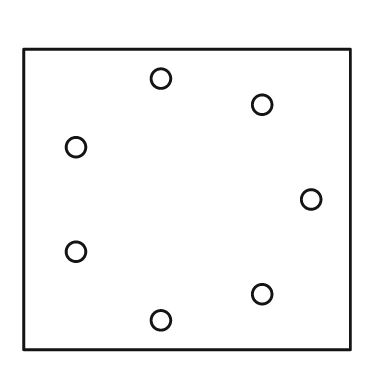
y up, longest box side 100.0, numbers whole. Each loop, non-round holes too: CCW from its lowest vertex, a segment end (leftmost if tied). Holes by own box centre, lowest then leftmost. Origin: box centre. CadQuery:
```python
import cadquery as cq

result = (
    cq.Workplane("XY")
    .moveTo(-50.0, -46.0)
    .lineTo(50.0, -46.0)
    .lineTo(50.0, 46.0)
    .lineTo(-50.0, 46.0)
    .close()
    .moveTo(-8.0, -37.0)
    .circle(3.0)
    .moveTo(23.0, -29.0)
    .circle(3.0)
    .moveTo(-34.0, -16.0)
    .circle(3.0)
    .moveTo(38.0, 0.0)
    .circle(3.0)
    .moveTo(-34.0, 16.0)
    .circle(3.0)
    .moveTo(23.0, 29.0)
    .circle(3.0)
    .moveTo(-8.0, 37.0)
    .circle(3.0)
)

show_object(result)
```